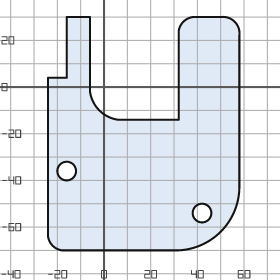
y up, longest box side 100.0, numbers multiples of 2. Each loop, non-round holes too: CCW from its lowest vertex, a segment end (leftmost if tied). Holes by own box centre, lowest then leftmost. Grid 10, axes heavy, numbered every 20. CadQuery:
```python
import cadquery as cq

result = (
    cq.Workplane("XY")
    .moveTo(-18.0, -70.0)
    .lineTo(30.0, -70.0)
    .threePointArc((50.0, -62.0), (58.0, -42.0))
    .lineTo(58.0, 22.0)
    .threePointArc((56.0, 28.0), (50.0, 30.0))
    .lineTo(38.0, 30.0)
    .threePointArc((34.0, 28.0), (32.0, 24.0))
    .lineTo(32.0, -14.0)
    .lineTo(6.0, -14.0)
    .threePointArc((-2.0, -10.0), (-6.0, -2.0))
    .lineTo(-6.0, 30.0)
    .lineTo(-16.0, 30.0)
    .lineTo(-16.0, 4.0)
    .lineTo(-24.0, 4.0)
    .lineTo(-24.0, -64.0)
    .threePointArc((-22.0, -68.0), (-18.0, -70.0))
    .close()
    .moveTo(42.0, -54.0)
    .circle(4.0)
    .moveTo(-16.0, -36.0)
    .circle(4.0)
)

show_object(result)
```